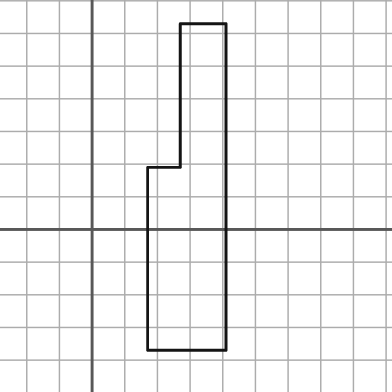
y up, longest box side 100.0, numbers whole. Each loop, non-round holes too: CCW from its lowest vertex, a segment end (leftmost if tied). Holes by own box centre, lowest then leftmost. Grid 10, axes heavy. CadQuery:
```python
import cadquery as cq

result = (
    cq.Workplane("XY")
    .moveTo(17.0, -37.0)
    .lineTo(41.0, -37.0)
    .lineTo(41.0, 63.0)
    .lineTo(27.0, 63.0)
    .lineTo(27.0, 19.0)
    .lineTo(17.0, 19.0)
    .close()
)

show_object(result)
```